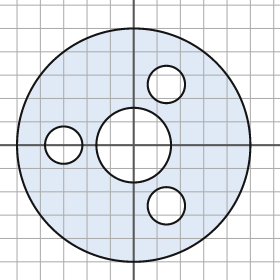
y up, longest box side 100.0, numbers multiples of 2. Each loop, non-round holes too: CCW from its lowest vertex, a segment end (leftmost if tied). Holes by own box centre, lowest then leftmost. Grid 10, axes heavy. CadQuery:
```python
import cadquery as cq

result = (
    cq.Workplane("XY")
    .moveTo(0.0, 0.0)
    .circle(50.0)
    .moveTo(14.0, -26.0)
    .circle(8.0)
    .moveTo(-30.0, 0.0)
    .circle(8.0)
    .moveTo(0.0, 0.0)
    .circle(16.0)
    .moveTo(14.0, 26.0)
    .circle(8.0)
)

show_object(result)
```